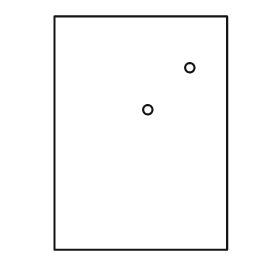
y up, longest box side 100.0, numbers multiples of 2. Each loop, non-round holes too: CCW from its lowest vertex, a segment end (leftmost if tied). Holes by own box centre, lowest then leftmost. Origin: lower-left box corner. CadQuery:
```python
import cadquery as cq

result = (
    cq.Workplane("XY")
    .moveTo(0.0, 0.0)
    .lineTo(74.0, 0.0)
    .lineTo(74.0, 100.0)
    .lineTo(0.0, 100.0)
    .close()
    .moveTo(40.0, 60.0)
    .circle(2.0)
    .moveTo(58.0, 78.0)
    .circle(2.0)
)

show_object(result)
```